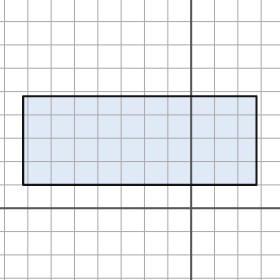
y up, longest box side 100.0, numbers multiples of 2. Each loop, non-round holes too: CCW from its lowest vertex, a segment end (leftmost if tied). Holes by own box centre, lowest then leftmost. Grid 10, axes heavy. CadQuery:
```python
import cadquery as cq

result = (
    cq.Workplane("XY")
    .moveTo(-72.0, 10.0)
    .lineTo(28.0, 10.0)
    .lineTo(28.0, 48.0)
    .lineTo(-72.0, 48.0)
    .close()
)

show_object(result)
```